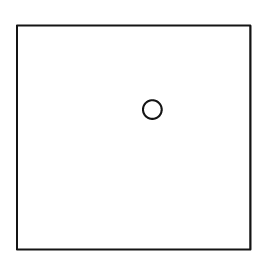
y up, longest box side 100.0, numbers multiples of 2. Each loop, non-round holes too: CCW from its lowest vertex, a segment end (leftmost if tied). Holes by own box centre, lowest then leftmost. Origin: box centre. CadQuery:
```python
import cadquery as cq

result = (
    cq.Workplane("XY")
    .moveTo(-50.0, -48.0)
    .lineTo(50.0, -48.0)
    .lineTo(50.0, 48.0)
    .lineTo(-50.0, 48.0)
    .close()
    .moveTo(8.0, 12.0)
    .circle(4.0)
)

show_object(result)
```